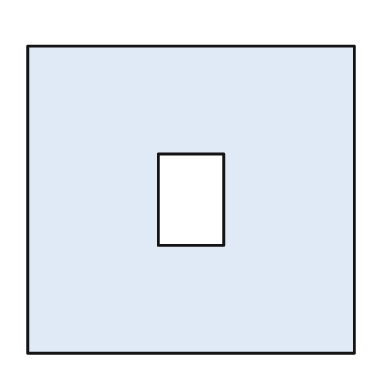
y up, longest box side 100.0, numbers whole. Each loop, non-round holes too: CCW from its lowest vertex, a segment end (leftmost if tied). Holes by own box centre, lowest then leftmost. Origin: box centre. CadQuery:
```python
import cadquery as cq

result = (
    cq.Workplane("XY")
    .moveTo(-50.0, -47.0)
    .lineTo(50.0, -47.0)
    .lineTo(50.0, 47.0)
    .lineTo(-50.0, 47.0)
    .close()
    .moveTo(-10.0, -14.0)
    .lineTo(10.0, -14.0)
    .lineTo(10.0, 14.0)
    .lineTo(-10.0, 14.0)
    .close()
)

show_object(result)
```